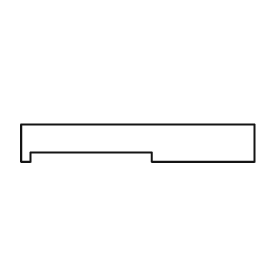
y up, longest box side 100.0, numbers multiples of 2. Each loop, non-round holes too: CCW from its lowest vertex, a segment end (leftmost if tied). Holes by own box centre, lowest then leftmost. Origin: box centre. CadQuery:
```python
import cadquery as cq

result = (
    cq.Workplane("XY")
    .moveTo(-50.0, -8.0)
    .lineTo(-46.0, -8.0)
    .lineTo(-46.0, -4.0)
    .lineTo(6.0, -4.0)
    .lineTo(6.0, -8.0)
    .lineTo(50.0, -8.0)
    .lineTo(50.0, 8.0)
    .lineTo(-50.0, 8.0)
    .close()
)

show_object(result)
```